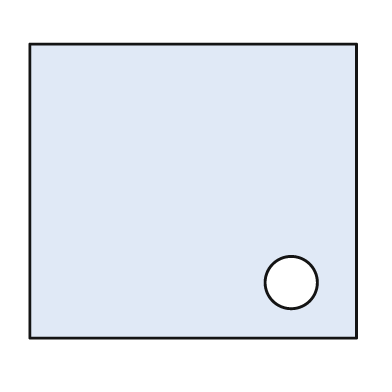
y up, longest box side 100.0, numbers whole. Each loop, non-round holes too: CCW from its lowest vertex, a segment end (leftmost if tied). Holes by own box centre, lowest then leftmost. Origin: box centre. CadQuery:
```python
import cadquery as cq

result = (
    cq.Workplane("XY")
    .moveTo(-50.0, -45.0)
    .lineTo(50.0, -45.0)
    .lineTo(50.0, 45.0)
    .lineTo(-50.0, 45.0)
    .close()
    .moveTo(30.0, -28.0)
    .circle(8.0)
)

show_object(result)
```